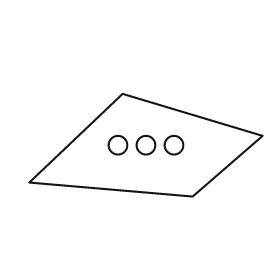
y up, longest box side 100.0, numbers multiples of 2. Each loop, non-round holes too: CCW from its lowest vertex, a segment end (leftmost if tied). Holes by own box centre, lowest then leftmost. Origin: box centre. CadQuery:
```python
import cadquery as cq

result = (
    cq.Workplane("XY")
    .moveTo(20.0, -22.0)
    .lineTo(50.0, 4.0)
    .lineTo(-10.0, 22.0)
    .lineTo(-50.0, -16.0)
    .close()
    .moveTo(-12.0, 0.0)
    .circle(4.0)
    .moveTo(0.0, 0.0)
    .circle(4.0)
    .moveTo(12.0, 0.0)
    .circle(4.0)
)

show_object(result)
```